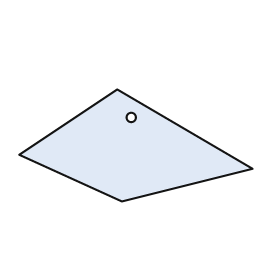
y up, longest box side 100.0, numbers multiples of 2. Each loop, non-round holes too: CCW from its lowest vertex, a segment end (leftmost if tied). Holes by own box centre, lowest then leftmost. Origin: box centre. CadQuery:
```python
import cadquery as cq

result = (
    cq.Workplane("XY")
    .moveTo(-6.0, -24.0)
    .lineTo(50.0, -10.0)
    .lineTo(-8.0, 24.0)
    .lineTo(-50.0, -4.0)
    .close()
    .moveTo(-2.0, 12.0)
    .circle(2.0)
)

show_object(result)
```